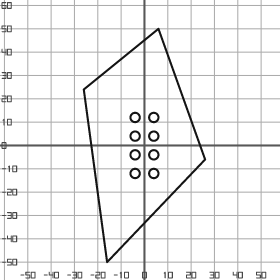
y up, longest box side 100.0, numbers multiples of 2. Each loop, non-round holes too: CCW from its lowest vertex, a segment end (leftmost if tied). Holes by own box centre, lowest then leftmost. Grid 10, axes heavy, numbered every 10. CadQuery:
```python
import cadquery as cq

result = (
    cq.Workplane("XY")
    .moveTo(-16.0, -50.0)
    .lineTo(26.0, -6.0)
    .lineTo(6.0, 50.0)
    .lineTo(-26.0, 24.0)
    .close()
    .moveTo(-4.0, -12.0)
    .circle(2.0)
    .moveTo(4.0, -12.0)
    .circle(2.0)
    .moveTo(-4.0, -4.0)
    .circle(2.0)
    .moveTo(4.0, -4.0)
    .circle(2.0)
    .moveTo(-4.0, 4.0)
    .circle(2.0)
    .moveTo(4.0, 4.0)
    .circle(2.0)
    .moveTo(-4.0, 12.0)
    .circle(2.0)
    .moveTo(4.0, 12.0)
    .circle(2.0)
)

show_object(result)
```